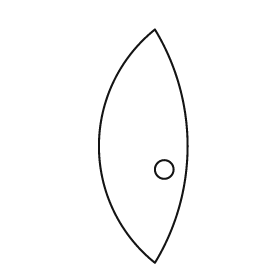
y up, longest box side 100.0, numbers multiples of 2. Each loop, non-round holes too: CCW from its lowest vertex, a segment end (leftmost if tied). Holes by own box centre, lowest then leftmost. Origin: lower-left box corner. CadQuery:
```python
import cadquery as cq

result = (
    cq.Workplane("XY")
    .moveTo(24.0, 0.0)
    .threePointArc((38.0, 50.0), (24.0, 100.0))
    .threePointArc((0.0, 50.0), (24.0, 0.0))
    .close()
    .moveTo(28.0, 40.0)
    .circle(4.0)
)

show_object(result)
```